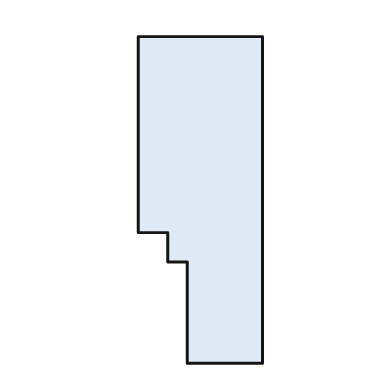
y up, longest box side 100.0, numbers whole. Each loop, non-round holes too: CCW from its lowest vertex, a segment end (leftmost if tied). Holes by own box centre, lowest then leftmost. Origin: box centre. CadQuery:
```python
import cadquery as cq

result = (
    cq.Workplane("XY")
    .moveTo(-4.0, -50.0)
    .lineTo(19.0, -50.0)
    .lineTo(19.0, 50.0)
    .lineTo(-19.0, 50.0)
    .lineTo(-19.0, -10.0)
    .lineTo(-10.0, -10.0)
    .lineTo(-10.0, -19.0)
    .lineTo(-4.0, -19.0)
    .close()
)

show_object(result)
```